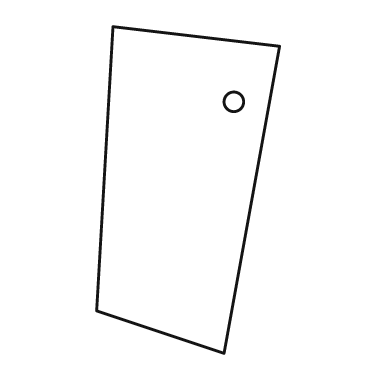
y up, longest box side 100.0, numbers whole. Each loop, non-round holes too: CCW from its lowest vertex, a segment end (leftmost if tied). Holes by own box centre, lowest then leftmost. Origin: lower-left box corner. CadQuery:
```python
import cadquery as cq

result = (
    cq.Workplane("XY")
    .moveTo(39.0, 0.0)
    .lineTo(56.0, 94.0)
    .lineTo(5.0, 100.0)
    .lineTo(0.0, 13.0)
    .close()
    .moveTo(42.0, 77.0)
    .circle(3.0)
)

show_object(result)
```